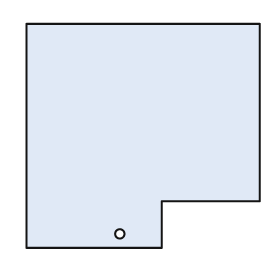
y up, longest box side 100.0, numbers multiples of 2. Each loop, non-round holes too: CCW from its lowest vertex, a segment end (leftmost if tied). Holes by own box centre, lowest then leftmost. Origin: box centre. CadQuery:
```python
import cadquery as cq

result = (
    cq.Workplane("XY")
    .moveTo(-50.0, -48.0)
    .lineTo(8.0, -48.0)
    .lineTo(8.0, -28.0)
    .lineTo(50.0, -28.0)
    .lineTo(50.0, 48.0)
    .lineTo(-50.0, 48.0)
    .close()
    .moveTo(-10.0, -42.0)
    .circle(2.0)
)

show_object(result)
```